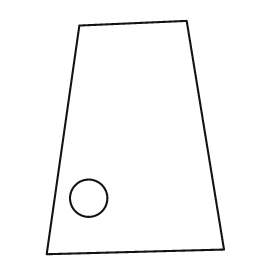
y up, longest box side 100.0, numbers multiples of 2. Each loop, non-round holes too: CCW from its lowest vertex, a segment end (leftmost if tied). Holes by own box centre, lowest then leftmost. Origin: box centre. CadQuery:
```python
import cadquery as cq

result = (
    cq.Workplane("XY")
    .moveTo(-38.0, -50.0)
    .lineTo(38.0, -48.0)
    .lineTo(22.0, 50.0)
    .lineTo(-24.0, 48.0)
    .close()
    .moveTo(-20.0, -26.0)
    .circle(8.0)
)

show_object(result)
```